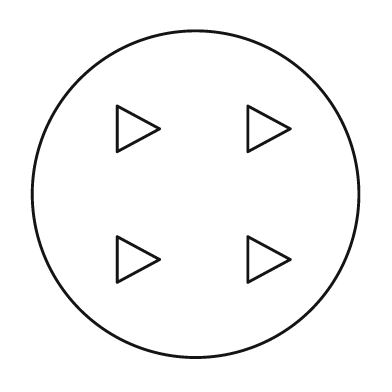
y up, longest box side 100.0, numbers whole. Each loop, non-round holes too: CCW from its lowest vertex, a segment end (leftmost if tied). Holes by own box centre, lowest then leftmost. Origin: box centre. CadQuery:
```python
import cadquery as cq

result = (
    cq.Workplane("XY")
    .moveTo(0.0, 0.0)
    .circle(50.0)
    .moveTo(-24.0, -27.0)
    .lineTo(-11.0, -20.0)
    .lineTo(-24.0, -13.0)
    .close()
    .moveTo(16.0, -27.0)
    .lineTo(29.0, -20.0)
    .lineTo(16.0, -13.0)
    .close()
    .moveTo(-24.0, 13.0)
    .lineTo(-11.0, 20.0)
    .lineTo(-24.0, 27.0)
    .close()
    .moveTo(16.0, 13.0)
    .lineTo(29.0, 20.0)
    .lineTo(16.0, 27.0)
    .close()
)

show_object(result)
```